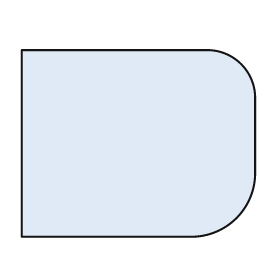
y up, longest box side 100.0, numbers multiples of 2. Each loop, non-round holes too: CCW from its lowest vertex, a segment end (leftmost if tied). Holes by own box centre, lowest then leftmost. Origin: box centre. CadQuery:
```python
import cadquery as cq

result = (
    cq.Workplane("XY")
    .moveTo(-50.0, -40.0)
    .lineTo(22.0, -40.0)
    .threePointArc((42.0, -32.0), (50.0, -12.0))
    .lineTo(50.0, 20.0)
    .threePointArc((44.0, 34.0), (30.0, 40.0))
    .lineTo(-50.0, 40.0)
    .close()
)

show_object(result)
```